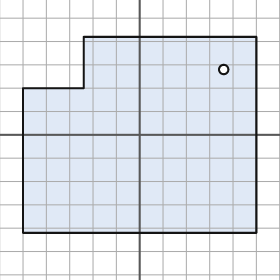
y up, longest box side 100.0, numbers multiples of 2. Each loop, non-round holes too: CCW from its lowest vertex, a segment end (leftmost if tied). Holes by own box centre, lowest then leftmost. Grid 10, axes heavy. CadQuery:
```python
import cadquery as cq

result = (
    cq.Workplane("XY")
    .moveTo(-50.0, -42.0)
    .lineTo(50.0, -42.0)
    .lineTo(50.0, 42.0)
    .lineTo(-24.0, 42.0)
    .lineTo(-24.0, 20.0)
    .lineTo(-50.0, 20.0)
    .close()
    .moveTo(36.0, 28.0)
    .circle(2.0)
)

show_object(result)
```